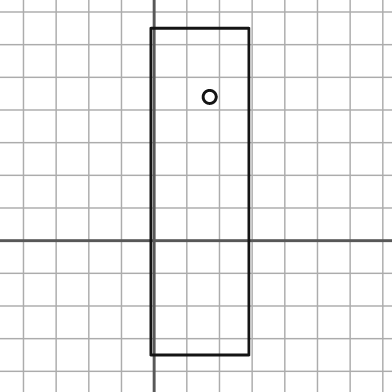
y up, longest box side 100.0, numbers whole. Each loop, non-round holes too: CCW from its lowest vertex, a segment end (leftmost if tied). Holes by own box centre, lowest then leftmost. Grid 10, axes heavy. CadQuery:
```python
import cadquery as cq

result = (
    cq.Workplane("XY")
    .moveTo(-1.0, -35.0)
    .lineTo(29.0, -35.0)
    .lineTo(29.0, 65.0)
    .lineTo(-1.0, 65.0)
    .close()
    .moveTo(17.0, 44.0)
    .circle(2.0)
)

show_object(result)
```